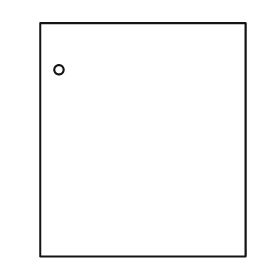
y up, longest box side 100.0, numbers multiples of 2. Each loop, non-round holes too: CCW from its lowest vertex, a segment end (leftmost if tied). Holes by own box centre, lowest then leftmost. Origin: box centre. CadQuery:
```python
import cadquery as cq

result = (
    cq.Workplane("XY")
    .moveTo(-44.0, -50.0)
    .lineTo(44.0, -50.0)
    .lineTo(44.0, 50.0)
    .lineTo(-44.0, 50.0)
    .close()
    .moveTo(-36.0, 30.0)
    .circle(2.0)
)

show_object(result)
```